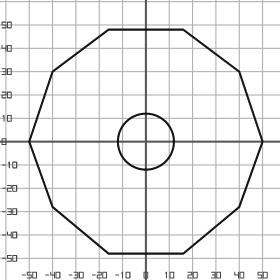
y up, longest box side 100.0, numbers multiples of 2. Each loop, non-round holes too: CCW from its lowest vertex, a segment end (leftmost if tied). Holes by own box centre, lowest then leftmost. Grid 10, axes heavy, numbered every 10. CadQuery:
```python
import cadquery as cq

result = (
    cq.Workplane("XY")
    .moveTo(-16.0, -48.0)
    .lineTo(16.0, -48.0)
    .lineTo(40.0, -28.0)
    .lineTo(50.0, 0.0)
    .lineTo(40.0, 30.0)
    .lineTo(16.0, 48.0)
    .lineTo(-16.0, 48.0)
    .lineTo(-40.0, 30.0)
    .lineTo(-50.0, 0.0)
    .lineTo(-40.0, -28.0)
    .close()
    .moveTo(0.0, 0.0)
    .circle(12.0)
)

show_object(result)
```